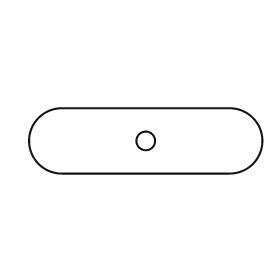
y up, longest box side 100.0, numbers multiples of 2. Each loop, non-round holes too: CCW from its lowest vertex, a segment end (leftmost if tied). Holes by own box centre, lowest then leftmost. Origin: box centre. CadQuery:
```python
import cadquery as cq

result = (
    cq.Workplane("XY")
    .moveTo(-36.0, -14.0)
    .lineTo(36.0, -14.0)
    .threePointArc((50.0, 0.0), (36.0, 14.0))
    .lineTo(-36.0, 14.0)
    .threePointArc((-50.0, 0.0), (-36.0, -14.0))
    .close()
    .moveTo(0.0, 0.0)
    .circle(4.0)
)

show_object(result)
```